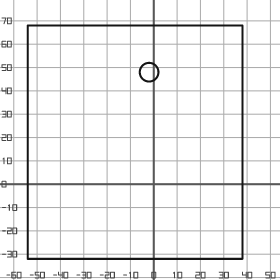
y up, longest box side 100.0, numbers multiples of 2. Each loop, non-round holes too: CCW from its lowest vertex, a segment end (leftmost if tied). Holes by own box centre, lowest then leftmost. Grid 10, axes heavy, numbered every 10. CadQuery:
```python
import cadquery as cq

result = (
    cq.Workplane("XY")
    .moveTo(-54.0, -32.0)
    .lineTo(38.0, -32.0)
    .lineTo(38.0, 68.0)
    .lineTo(-54.0, 68.0)
    .close()
    .moveTo(-2.0, 48.0)
    .circle(4.0)
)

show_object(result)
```